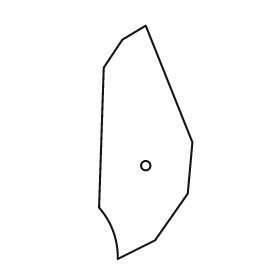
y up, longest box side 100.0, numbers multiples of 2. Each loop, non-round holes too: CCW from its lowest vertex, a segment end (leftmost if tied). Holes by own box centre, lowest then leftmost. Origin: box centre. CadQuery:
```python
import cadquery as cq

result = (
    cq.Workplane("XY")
    .moveTo(-12.0, -50.0)
    .lineTo(4.0, -42.0)
    .lineTo(18.0, -22.0)
    .lineTo(20.0, 0.0)
    .lineTo(0.0, 50.0)
    .lineTo(-10.0, 44.0)
    .lineTo(-18.0, 32.0)
    .lineTo(-20.0, -28.0)
    .threePointArc((-14.0, -38.0), (-12.0, -50.0))
    .close()
    .moveTo(0.0, -10.0)
    .circle(2.0)
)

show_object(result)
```